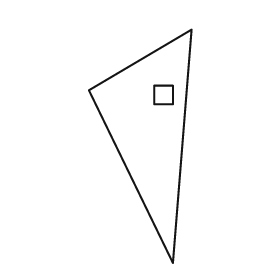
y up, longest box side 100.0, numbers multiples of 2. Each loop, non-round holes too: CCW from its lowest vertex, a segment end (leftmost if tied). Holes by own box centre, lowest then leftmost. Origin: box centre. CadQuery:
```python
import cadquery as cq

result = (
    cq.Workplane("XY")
    .moveTo(14.0, -50.0)
    .lineTo(22.0, 50.0)
    .lineTo(-22.0, 24.0)
    .close()
    .moveTo(6.0, 18.0)
    .lineTo(14.0, 18.0)
    .lineTo(14.0, 26.0)
    .lineTo(6.0, 26.0)
    .close()
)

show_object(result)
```